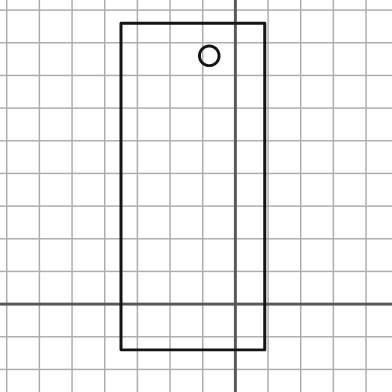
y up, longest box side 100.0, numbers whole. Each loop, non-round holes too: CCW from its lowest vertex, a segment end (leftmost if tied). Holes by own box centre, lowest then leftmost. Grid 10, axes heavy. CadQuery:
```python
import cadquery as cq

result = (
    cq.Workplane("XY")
    .moveTo(-35.0, -14.0)
    .lineTo(9.0, -14.0)
    .lineTo(9.0, 86.0)
    .lineTo(-35.0, 86.0)
    .close()
    .moveTo(-8.0, 76.0)
    .circle(3.0)
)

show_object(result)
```